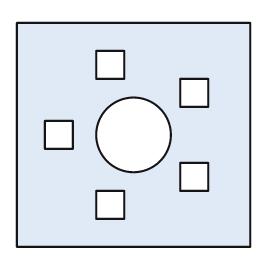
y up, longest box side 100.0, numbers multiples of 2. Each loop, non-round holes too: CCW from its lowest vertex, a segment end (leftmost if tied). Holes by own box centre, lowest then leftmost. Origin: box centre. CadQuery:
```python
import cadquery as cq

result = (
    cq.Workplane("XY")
    .moveTo(-50.0, -48.0)
    .lineTo(50.0, -48.0)
    .lineTo(50.0, 48.0)
    .lineTo(-50.0, 48.0)
    .close()
    .moveTo(-16.0, -36.0)
    .lineTo(-4.0, -36.0)
    .lineTo(-4.0, -24.0)
    .lineTo(-16.0, -24.0)
    .close()
    .moveTo(20.0, -24.0)
    .lineTo(32.0, -24.0)
    .lineTo(32.0, -12.0)
    .lineTo(20.0, -12.0)
    .close()
    .moveTo(-38.0, -6.0)
    .lineTo(-26.0, -6.0)
    .lineTo(-26.0, 6.0)
    .lineTo(-38.0, 6.0)
    .close()
    .moveTo(0.0, 0.0)
    .circle(16.0)
    .moveTo(20.0, 12.0)
    .lineTo(32.0, 12.0)
    .lineTo(32.0, 24.0)
    .lineTo(20.0, 24.0)
    .close()
    .moveTo(-16.0, 24.0)
    .lineTo(-4.0, 24.0)
    .lineTo(-4.0, 36.0)
    .lineTo(-16.0, 36.0)
    .close()
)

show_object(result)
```